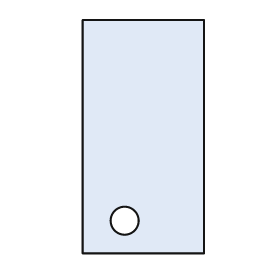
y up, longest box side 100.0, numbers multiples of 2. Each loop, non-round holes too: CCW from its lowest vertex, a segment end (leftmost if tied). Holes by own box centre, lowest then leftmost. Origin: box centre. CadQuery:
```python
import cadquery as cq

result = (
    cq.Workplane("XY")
    .moveTo(-26.0, -50.0)
    .lineTo(26.0, -50.0)
    .lineTo(26.0, 50.0)
    .lineTo(-26.0, 50.0)
    .close()
    .moveTo(-8.0, -36.0)
    .circle(6.0)
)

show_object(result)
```